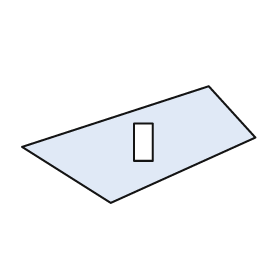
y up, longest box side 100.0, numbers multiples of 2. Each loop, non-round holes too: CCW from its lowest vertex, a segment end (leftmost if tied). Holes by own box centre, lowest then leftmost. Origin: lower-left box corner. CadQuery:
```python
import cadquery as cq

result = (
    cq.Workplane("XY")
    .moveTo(38.0, 0.0)
    .lineTo(100.0, 28.0)
    .lineTo(80.0, 50.0)
    .lineTo(0.0, 24.0)
    .close()
    .moveTo(48.0, 18.0)
    .lineTo(56.0, 18.0)
    .lineTo(56.0, 34.0)
    .lineTo(48.0, 34.0)
    .close()
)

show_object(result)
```